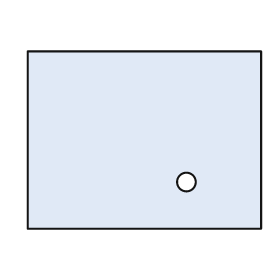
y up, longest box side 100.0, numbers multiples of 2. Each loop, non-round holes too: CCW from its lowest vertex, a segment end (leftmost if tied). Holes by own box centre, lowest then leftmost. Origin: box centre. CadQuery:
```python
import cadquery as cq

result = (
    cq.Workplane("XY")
    .moveTo(-50.0, -38.0)
    .lineTo(50.0, -38.0)
    .lineTo(50.0, 38.0)
    .lineTo(-50.0, 38.0)
    .close()
    .moveTo(18.0, -18.0)
    .circle(4.0)
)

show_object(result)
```